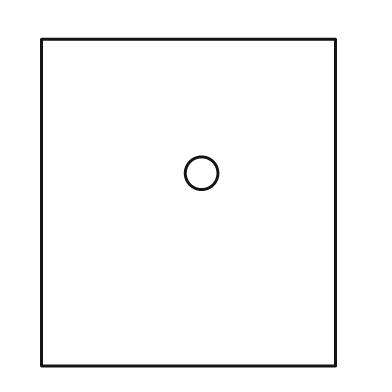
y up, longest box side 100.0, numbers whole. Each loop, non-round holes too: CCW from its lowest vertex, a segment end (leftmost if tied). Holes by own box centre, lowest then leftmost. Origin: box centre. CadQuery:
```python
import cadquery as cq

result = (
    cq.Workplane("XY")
    .moveTo(-45.0, -50.0)
    .lineTo(45.0, -50.0)
    .lineTo(45.0, 50.0)
    .lineTo(-45.0, 50.0)
    .close()
    .moveTo(4.0, 9.0)
    .circle(5.0)
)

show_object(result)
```